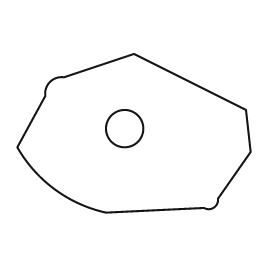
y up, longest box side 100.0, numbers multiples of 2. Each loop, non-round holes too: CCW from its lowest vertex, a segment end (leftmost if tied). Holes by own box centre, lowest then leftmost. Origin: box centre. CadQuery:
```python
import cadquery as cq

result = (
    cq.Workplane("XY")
    .moveTo(-12.0, -34.0)
    .lineTo(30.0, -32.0)
    .threePointArc((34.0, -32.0), (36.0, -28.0))
    .lineTo(50.0, -8.0)
    .lineTo(48.0, 10.0)
    .lineTo(0.0, 34.0)
    .lineTo(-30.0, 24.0)
    .threePointArc((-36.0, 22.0), (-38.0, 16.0))
    .lineTo(-50.0, -6.0)
    .threePointArc((-34.0, -24.0), (-12.0, -34.0))
    .close()
    .moveTo(-4.0, 2.0)
    .circle(8.0)
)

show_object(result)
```